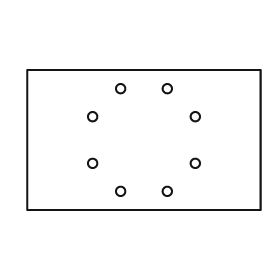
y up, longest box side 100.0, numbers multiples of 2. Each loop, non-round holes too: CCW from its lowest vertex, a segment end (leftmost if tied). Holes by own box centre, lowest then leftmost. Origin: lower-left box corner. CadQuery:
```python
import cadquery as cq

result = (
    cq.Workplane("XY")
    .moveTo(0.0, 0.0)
    .lineTo(100.0, 0.0)
    .lineTo(100.0, 60.0)
    .lineTo(0.0, 60.0)
    .close()
    .moveTo(40.0, 8.0)
    .circle(2.0)
    .moveTo(60.0, 8.0)
    .circle(2.0)
    .moveTo(28.0, 20.0)
    .circle(2.0)
    .moveTo(72.0, 20.0)
    .circle(2.0)
    .moveTo(28.0, 40.0)
    .circle(2.0)
    .moveTo(72.0, 40.0)
    .circle(2.0)
    .moveTo(40.0, 52.0)
    .circle(2.0)
    .moveTo(60.0, 52.0)
    .circle(2.0)
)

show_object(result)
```